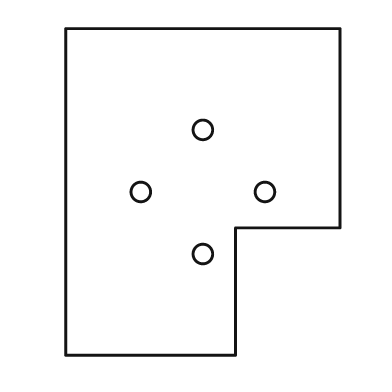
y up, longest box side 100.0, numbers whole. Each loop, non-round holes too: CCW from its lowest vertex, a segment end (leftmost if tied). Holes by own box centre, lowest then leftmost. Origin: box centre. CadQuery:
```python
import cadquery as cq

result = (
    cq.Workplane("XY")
    .moveTo(-42.0, -50.0)
    .lineTo(10.0, -50.0)
    .lineTo(10.0, -11.0)
    .lineTo(42.0, -11.0)
    .lineTo(42.0, 50.0)
    .lineTo(-42.0, 50.0)
    .close()
    .moveTo(0.0, -19.0)
    .circle(3.0)
    .moveTo(-19.0, 0.0)
    .circle(3.0)
    .moveTo(19.0, 0.0)
    .circle(3.0)
    .moveTo(0.0, 19.0)
    .circle(3.0)
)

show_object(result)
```